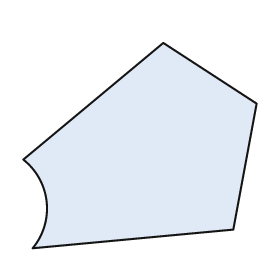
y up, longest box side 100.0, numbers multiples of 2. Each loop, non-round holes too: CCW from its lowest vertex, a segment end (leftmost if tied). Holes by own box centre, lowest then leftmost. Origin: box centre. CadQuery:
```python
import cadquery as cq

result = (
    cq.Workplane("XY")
    .moveTo(-46.0, -44.0)
    .lineTo(40.0, -36.0)
    .lineTo(50.0, 18.0)
    .lineTo(10.0, 44.0)
    .lineTo(-50.0, -6.0)
    .threePointArc((-40.0, -24.0), (-46.0, -44.0))
    .close()
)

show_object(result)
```